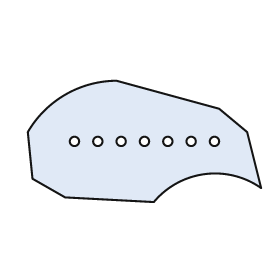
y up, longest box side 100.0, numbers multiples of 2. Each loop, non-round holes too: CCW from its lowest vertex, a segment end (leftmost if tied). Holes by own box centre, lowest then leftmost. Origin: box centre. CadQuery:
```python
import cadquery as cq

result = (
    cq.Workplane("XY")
    .moveTo(4.0, -26.0)
    .threePointArc((26.0, -14.0), (50.0, -20.0))
    .lineTo(44.0, 4.0)
    .lineTo(32.0, 14.0)
    .lineTo(-12.0, 26.0)
    .threePointArc((-34.0, 20.0), (-50.0, 4.0))
    .lineTo(-48.0, -16.0)
    .lineTo(-34.0, -24.0)
    .close()
    .moveTo(-30.0, 0.0)
    .circle(2.0)
    .moveTo(-20.0, 0.0)
    .circle(2.0)
    .moveTo(-10.0, 0.0)
    .circle(2.0)
    .moveTo(0.0, 0.0)
    .circle(2.0)
    .moveTo(10.0, 0.0)
    .circle(2.0)
    .moveTo(20.0, 0.0)
    .circle(2.0)
    .moveTo(30.0, 0.0)
    .circle(2.0)
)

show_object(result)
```